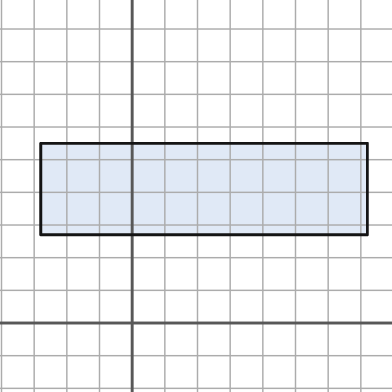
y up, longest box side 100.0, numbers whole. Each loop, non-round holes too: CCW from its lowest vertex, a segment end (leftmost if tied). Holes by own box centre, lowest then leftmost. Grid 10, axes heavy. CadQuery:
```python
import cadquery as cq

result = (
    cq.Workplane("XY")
    .moveTo(-28.0, 27.0)
    .lineTo(72.0, 27.0)
    .lineTo(72.0, 55.0)
    .lineTo(-28.0, 55.0)
    .close()
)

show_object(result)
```